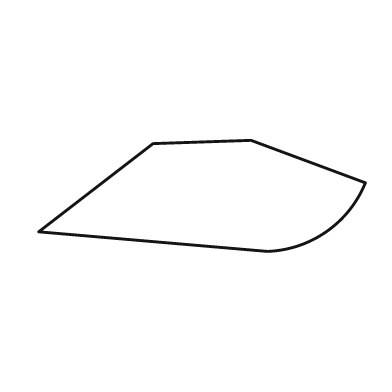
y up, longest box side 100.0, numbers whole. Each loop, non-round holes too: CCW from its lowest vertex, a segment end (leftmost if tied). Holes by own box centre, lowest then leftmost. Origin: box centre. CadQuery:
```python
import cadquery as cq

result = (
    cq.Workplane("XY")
    .moveTo(20.0, -17.0)
    .threePointArc((38.0, -11.0), (50.0, 4.0))
    .lineTo(15.0, 17.0)
    .lineTo(-15.0, 16.0)
    .lineTo(-50.0, -11.0)
    .close()
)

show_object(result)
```